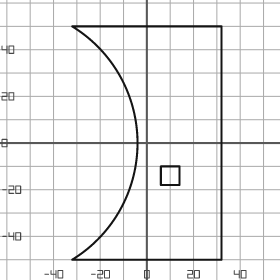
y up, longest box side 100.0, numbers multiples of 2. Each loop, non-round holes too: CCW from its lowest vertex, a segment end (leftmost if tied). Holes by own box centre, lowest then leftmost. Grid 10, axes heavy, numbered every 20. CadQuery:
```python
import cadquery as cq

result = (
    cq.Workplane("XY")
    .moveTo(-32.0, -50.0)
    .lineTo(32.0, -50.0)
    .lineTo(32.0, 50.0)
    .lineTo(-32.0, 50.0)
    .threePointArc((-4.0, 0.0), (-32.0, -50.0))
    .close()
    .moveTo(6.0, -18.0)
    .lineTo(14.0, -18.0)
    .lineTo(14.0, -10.0)
    .lineTo(6.0, -10.0)
    .close()
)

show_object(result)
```